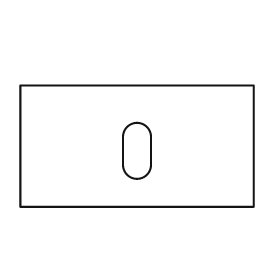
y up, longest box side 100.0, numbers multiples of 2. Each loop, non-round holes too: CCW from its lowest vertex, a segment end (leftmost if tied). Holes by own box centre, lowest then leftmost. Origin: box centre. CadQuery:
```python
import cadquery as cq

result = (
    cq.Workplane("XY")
    .moveTo(-50.0, -26.0)
    .lineTo(50.0, -26.0)
    .lineTo(50.0, 26.0)
    .lineTo(-50.0, 26.0)
    .close()
    .moveTo(-6.0, -8.0)
    .threePointArc((0.0, -14.0), (6.0, -8.0))
    .lineTo(6.0, 4.0)
    .threePointArc((0.0, 10.0), (-6.0, 4.0))
    .close()
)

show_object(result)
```